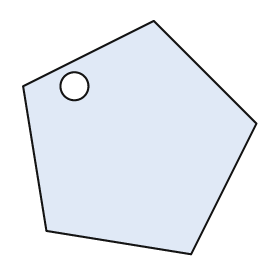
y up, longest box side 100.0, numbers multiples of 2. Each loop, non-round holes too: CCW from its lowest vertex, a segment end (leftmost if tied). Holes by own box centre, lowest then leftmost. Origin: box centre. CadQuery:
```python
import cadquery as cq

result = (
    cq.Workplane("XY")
    .moveTo(22.0, -50.0)
    .lineTo(50.0, 6.0)
    .lineTo(6.0, 50.0)
    .lineTo(-50.0, 22.0)
    .lineTo(-40.0, -40.0)
    .close()
    .moveTo(-28.0, 22.0)
    .circle(6.0)
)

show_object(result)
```